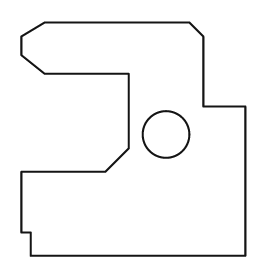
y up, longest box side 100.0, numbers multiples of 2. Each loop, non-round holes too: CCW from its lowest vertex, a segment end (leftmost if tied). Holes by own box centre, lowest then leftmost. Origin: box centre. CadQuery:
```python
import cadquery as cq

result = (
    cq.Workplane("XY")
    .moveTo(-44.0, -50.0)
    .lineTo(48.0, -50.0)
    .lineTo(48.0, 14.0)
    .lineTo(30.0, 14.0)
    .lineTo(30.0, 44.0)
    .lineTo(24.0, 50.0)
    .lineTo(-38.0, 50.0)
    .lineTo(-48.0, 44.0)
    .lineTo(-48.0, 36.0)
    .lineTo(-38.0, 28.0)
    .lineTo(-2.0, 28.0)
    .lineTo(-2.0, -4.0)
    .lineTo(-12.0, -14.0)
    .lineTo(-48.0, -14.0)
    .lineTo(-48.0, -40.0)
    .lineTo(-44.0, -40.0)
    .close()
    .moveTo(14.0, 2.0)
    .circle(10.0)
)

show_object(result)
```